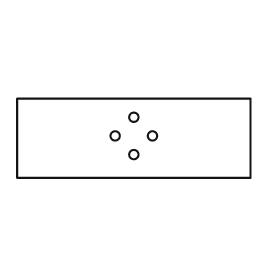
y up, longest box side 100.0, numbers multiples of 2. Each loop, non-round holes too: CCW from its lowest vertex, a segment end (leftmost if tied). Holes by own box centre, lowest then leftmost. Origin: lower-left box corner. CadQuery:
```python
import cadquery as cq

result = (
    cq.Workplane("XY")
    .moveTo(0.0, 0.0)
    .lineTo(100.0, 0.0)
    .lineTo(100.0, 34.0)
    .lineTo(0.0, 34.0)
    .close()
    .moveTo(50.0, 10.0)
    .circle(2.0)
    .moveTo(42.0, 18.0)
    .circle(2.0)
    .moveTo(58.0, 18.0)
    .circle(2.0)
    .moveTo(50.0, 26.0)
    .circle(2.0)
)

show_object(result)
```